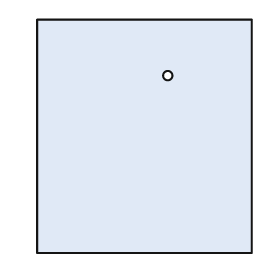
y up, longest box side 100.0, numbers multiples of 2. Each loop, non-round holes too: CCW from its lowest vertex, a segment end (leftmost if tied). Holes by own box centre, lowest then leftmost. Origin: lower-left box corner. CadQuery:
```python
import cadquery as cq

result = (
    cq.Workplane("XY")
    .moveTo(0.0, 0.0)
    .lineTo(92.0, 0.0)
    .lineTo(92.0, 100.0)
    .lineTo(0.0, 100.0)
    .close()
    .moveTo(56.0, 76.0)
    .circle(2.0)
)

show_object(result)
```